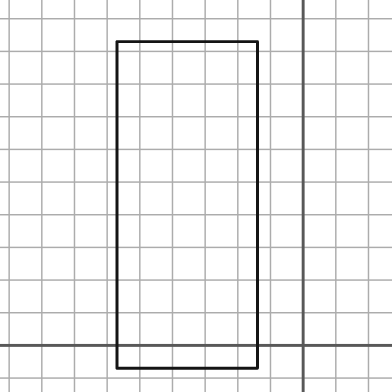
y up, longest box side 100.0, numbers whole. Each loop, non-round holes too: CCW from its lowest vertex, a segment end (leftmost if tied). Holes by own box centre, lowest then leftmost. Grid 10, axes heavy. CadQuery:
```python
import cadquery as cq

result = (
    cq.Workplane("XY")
    .moveTo(-57.0, -7.0)
    .lineTo(-14.0, -7.0)
    .lineTo(-14.0, 93.0)
    .lineTo(-57.0, 93.0)
    .close()
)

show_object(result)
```